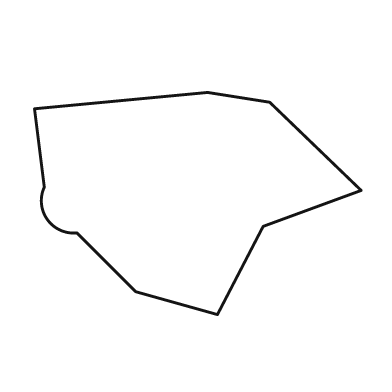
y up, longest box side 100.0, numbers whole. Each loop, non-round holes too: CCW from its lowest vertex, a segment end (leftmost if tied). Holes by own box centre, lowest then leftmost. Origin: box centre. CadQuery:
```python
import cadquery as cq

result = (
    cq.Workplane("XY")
    .moveTo(6.0, -34.0)
    .lineTo(20.0, -7.0)
    .lineTo(50.0, 4.0)
    .lineTo(22.0, 31.0)
    .lineTo(3.0, 34.0)
    .lineTo(-50.0, 29.0)
    .lineTo(-47.0, 5.0)
    .threePointArc((-46.0, -5.0), (-37.0, -9.0))
    .lineTo(-19.0, -27.0)
    .close()
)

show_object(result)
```